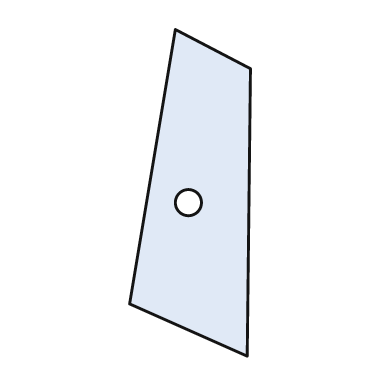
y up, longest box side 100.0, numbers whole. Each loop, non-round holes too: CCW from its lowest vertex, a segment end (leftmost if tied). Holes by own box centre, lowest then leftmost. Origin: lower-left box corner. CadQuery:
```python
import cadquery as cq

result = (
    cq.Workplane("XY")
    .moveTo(36.0, 0.0)
    .lineTo(37.0, 88.0)
    .lineTo(14.0, 100.0)
    .lineTo(0.0, 16.0)
    .close()
    .moveTo(18.0, 47.0)
    .circle(4.0)
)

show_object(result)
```